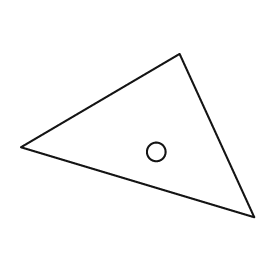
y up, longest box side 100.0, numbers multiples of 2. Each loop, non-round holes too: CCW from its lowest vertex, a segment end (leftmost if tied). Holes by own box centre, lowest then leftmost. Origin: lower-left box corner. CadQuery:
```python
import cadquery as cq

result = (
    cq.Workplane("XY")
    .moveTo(100.0, 0.0)
    .lineTo(68.0, 70.0)
    .lineTo(0.0, 30.0)
    .close()
    .moveTo(58.0, 28.0)
    .circle(4.0)
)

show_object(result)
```